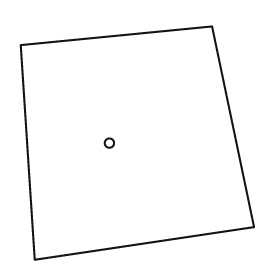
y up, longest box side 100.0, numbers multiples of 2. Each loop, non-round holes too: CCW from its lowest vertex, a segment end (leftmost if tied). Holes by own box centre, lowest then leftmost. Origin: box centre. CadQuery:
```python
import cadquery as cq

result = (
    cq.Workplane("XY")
    .moveTo(-44.0, -50.0)
    .lineTo(50.0, -36.0)
    .lineTo(32.0, 50.0)
    .lineTo(-50.0, 42.0)
    .close()
    .moveTo(-12.0, 0.0)
    .circle(2.0)
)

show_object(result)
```